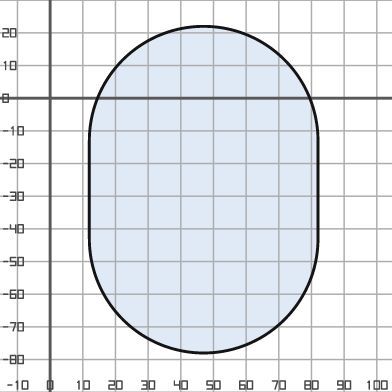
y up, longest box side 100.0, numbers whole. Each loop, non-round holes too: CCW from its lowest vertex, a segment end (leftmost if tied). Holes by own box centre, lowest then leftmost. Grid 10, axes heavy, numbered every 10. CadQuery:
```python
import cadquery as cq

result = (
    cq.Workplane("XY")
    .moveTo(12.0, -43.0)
    .threePointArc((47.0, -78.0), (82.0, -43.0))
    .lineTo(82.0, -13.0)
    .threePointArc((47.0, 22.0), (12.0, -13.0))
    .close()
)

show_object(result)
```